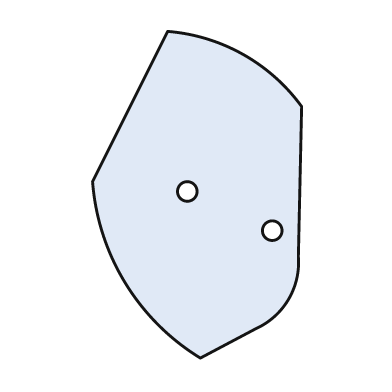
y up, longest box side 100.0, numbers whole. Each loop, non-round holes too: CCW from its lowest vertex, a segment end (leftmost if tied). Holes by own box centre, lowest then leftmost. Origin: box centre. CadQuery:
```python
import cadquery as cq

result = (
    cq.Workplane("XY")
    .moveTo(1.0, -50.0)
    .lineTo(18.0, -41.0)
    .threePointArc((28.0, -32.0), (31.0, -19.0))
    .lineTo(32.0, 27.0)
    .threePointArc((14.0, 43.0), (-9.0, 50.0))
    .lineTo(-32.0, 4.0)
    .threePointArc((-22.0, -27.0), (1.0, -50.0))
    .close()
    .moveTo(23.0, -11.0)
    .circle(3.0)
    .moveTo(-3.0, 1.0)
    .circle(3.0)
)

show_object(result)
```